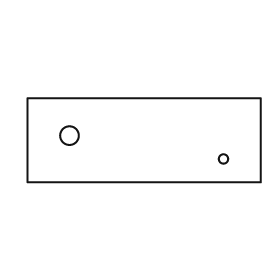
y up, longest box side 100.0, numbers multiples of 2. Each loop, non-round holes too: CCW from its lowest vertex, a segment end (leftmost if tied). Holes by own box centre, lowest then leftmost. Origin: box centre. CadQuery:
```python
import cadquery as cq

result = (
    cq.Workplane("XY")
    .moveTo(-50.0, -18.0)
    .lineTo(50.0, -18.0)
    .lineTo(50.0, 18.0)
    .lineTo(-50.0, 18.0)
    .close()
    .moveTo(34.0, -8.0)
    .circle(2.0)
    .moveTo(-32.0, 2.0)
    .circle(4.0)
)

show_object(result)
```